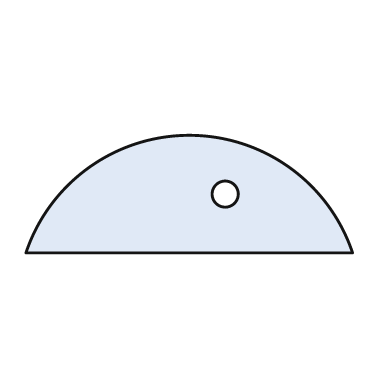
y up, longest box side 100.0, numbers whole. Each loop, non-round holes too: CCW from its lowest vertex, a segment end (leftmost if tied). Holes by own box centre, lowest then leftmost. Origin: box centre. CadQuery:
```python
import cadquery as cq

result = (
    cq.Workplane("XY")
    .moveTo(-50.0, -18.0)
    .lineTo(50.0, -18.0)
    .threePointArc((0.0, 18.0), (-50.0, -18.0))
    .close()
    .moveTo(11.0, 0.0)
    .circle(4.0)
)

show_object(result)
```